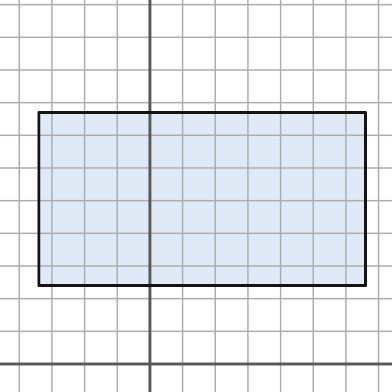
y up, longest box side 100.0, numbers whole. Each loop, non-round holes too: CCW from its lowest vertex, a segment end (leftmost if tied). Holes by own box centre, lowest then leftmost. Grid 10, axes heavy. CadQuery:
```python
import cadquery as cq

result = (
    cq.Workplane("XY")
    .moveTo(-34.0, 24.0)
    .lineTo(66.0, 24.0)
    .lineTo(66.0, 77.0)
    .lineTo(-34.0, 77.0)
    .close()
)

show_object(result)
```